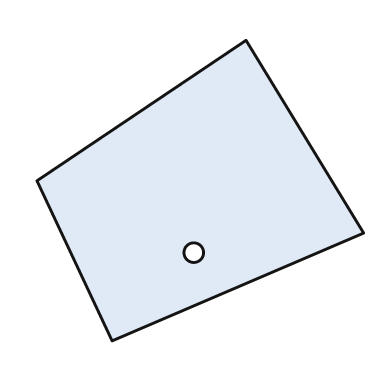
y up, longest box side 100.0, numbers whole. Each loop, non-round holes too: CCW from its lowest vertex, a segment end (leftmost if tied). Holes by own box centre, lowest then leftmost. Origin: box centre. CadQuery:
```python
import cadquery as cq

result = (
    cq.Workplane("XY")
    .moveTo(-27.0, -46.0)
    .lineTo(50.0, -13.0)
    .lineTo(14.0, 46.0)
    .lineTo(-50.0, 3.0)
    .close()
    .moveTo(-2.0, -19.0)
    .circle(3.0)
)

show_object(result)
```